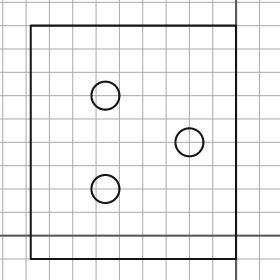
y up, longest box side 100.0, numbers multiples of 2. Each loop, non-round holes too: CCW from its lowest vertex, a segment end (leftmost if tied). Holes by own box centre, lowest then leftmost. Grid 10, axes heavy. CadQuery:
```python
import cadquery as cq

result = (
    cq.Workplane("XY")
    .moveTo(-88.0, -10.0)
    .lineTo(0.0, -10.0)
    .lineTo(0.0, 90.0)
    .lineTo(-88.0, 90.0)
    .close()
    .moveTo(-56.0, 20.0)
    .circle(6.0)
    .moveTo(-20.0, 40.0)
    .circle(6.0)
    .moveTo(-56.0, 60.0)
    .circle(6.0)
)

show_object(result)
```